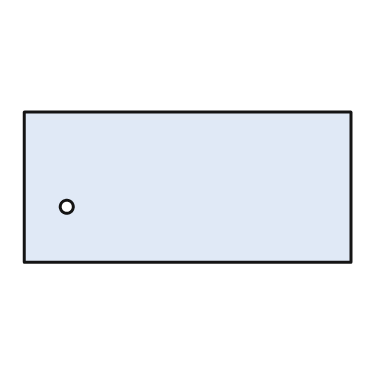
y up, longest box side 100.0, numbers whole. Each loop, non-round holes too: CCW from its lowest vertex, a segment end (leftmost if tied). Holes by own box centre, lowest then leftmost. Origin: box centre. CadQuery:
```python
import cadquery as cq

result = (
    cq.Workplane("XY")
    .moveTo(-50.0, -23.0)
    .lineTo(50.0, -23.0)
    .lineTo(50.0, 23.0)
    .lineTo(-50.0, 23.0)
    .close()
    .moveTo(-37.0, -6.0)
    .circle(2.0)
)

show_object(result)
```